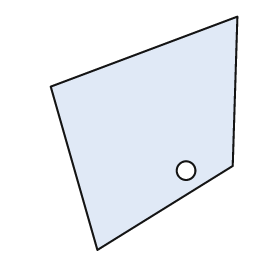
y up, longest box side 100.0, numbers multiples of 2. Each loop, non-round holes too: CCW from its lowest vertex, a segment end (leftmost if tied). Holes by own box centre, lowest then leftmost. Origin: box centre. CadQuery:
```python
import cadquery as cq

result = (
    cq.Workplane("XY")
    .moveTo(-20.0, -50.0)
    .lineTo(38.0, -14.0)
    .lineTo(40.0, 50.0)
    .lineTo(-40.0, 20.0)
    .close()
    .moveTo(18.0, -16.0)
    .circle(4.0)
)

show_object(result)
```